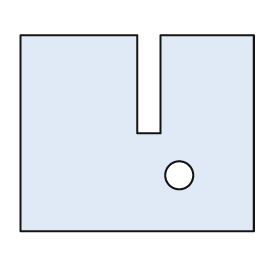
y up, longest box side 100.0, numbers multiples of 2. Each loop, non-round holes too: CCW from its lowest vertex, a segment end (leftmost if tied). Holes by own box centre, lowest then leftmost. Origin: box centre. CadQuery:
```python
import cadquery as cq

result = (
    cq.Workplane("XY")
    .moveTo(-50.0, -42.0)
    .lineTo(50.0, -42.0)
    .lineTo(50.0, 42.0)
    .lineTo(10.0, 42.0)
    .lineTo(10.0, 0.0)
    .lineTo(0.0, 0.0)
    .lineTo(0.0, 42.0)
    .lineTo(-50.0, 42.0)
    .close()
    .moveTo(18.0, -18.0)
    .circle(6.0)
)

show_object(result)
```